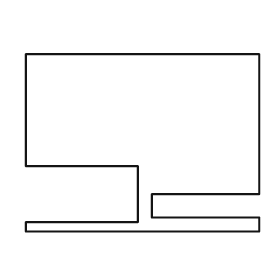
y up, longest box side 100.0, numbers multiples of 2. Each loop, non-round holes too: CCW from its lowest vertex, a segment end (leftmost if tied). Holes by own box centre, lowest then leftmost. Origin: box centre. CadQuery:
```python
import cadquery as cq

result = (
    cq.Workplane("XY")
    .moveTo(-50.0, -38.0)
    .lineTo(50.0, -38.0)
    .lineTo(50.0, -32.0)
    .lineTo(4.0, -32.0)
    .lineTo(4.0, -22.0)
    .lineTo(50.0, -22.0)
    .lineTo(50.0, 38.0)
    .lineTo(-50.0, 38.0)
    .lineTo(-50.0, -10.0)
    .lineTo(-2.0, -10.0)
    .lineTo(-2.0, -34.0)
    .lineTo(-50.0, -34.0)
    .close()
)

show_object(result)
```